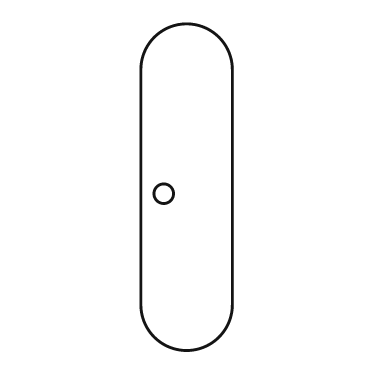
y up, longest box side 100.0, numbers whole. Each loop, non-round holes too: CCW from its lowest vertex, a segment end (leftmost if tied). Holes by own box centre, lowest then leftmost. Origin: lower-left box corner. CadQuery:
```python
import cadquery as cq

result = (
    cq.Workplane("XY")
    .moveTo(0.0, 14.0)
    .threePointArc((14.0, 0.0), (28.0, 14.0))
    .lineTo(28.0, 86.0)
    .threePointArc((14.0, 100.0), (0.0, 86.0))
    .close()
    .moveTo(7.0, 48.0)
    .circle(3.0)
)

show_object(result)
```